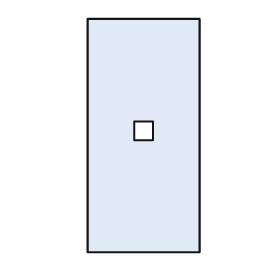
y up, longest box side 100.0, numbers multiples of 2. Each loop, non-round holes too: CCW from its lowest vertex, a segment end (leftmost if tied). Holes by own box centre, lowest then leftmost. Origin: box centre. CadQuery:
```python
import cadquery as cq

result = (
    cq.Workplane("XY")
    .moveTo(-24.0, -50.0)
    .lineTo(24.0, -50.0)
    .lineTo(24.0, 50.0)
    .lineTo(-24.0, 50.0)
    .close()
    .moveTo(-4.0, -2.0)
    .lineTo(4.0, -2.0)
    .lineTo(4.0, 6.0)
    .lineTo(-4.0, 6.0)
    .close()
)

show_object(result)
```